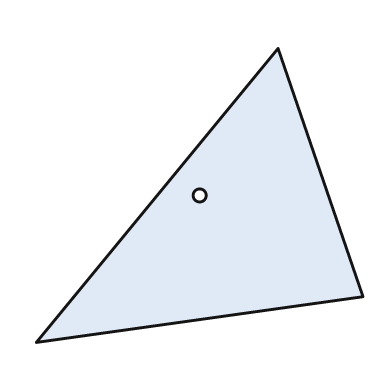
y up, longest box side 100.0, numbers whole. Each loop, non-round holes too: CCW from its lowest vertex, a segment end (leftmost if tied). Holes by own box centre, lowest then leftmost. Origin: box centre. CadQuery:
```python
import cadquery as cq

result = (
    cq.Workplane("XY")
    .moveTo(-50.0, -45.0)
    .lineTo(50.0, -31.0)
    .lineTo(24.0, 45.0)
    .close()
    .moveTo(0.0, 0.0)
    .circle(2.0)
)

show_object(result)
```